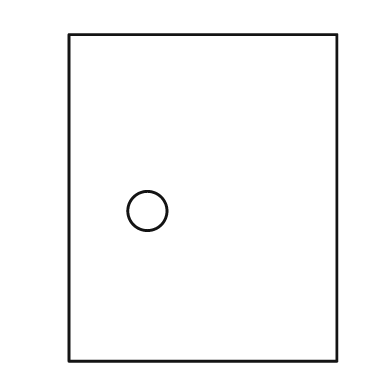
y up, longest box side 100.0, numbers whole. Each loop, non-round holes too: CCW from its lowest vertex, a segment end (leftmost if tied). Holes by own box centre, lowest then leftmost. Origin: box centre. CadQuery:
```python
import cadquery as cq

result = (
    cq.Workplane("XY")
    .moveTo(-41.0, -50.0)
    .lineTo(41.0, -50.0)
    .lineTo(41.0, 50.0)
    .lineTo(-41.0, 50.0)
    .close()
    .moveTo(-17.0, -4.0)
    .circle(6.0)
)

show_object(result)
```